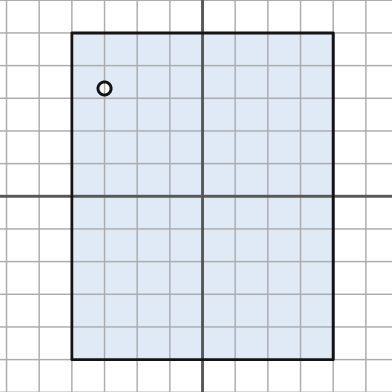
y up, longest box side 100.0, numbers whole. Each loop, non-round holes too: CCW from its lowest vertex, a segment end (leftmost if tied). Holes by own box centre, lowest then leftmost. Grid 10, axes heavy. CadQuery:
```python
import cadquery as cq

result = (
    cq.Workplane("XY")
    .moveTo(-40.0, -50.0)
    .lineTo(40.0, -50.0)
    .lineTo(40.0, 50.0)
    .lineTo(-40.0, 50.0)
    .close()
    .moveTo(-30.0, 33.0)
    .circle(2.0)
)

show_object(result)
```